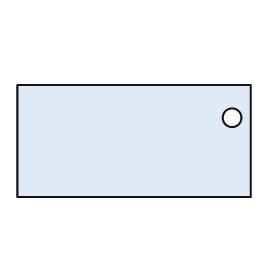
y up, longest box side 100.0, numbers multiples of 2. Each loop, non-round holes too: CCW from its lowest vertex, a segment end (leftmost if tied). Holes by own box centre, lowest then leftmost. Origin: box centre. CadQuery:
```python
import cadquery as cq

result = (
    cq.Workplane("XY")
    .moveTo(-50.0, -24.0)
    .lineTo(50.0, -24.0)
    .lineTo(50.0, 24.0)
    .lineTo(-50.0, 24.0)
    .close()
    .moveTo(42.0, 10.0)
    .circle(4.0)
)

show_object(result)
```